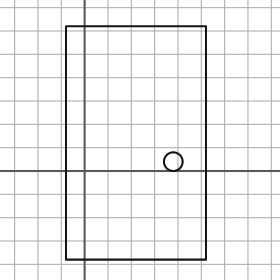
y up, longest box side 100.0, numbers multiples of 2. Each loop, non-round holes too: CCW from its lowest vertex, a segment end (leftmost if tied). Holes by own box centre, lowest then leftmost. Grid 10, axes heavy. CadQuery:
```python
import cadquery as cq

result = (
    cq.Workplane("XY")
    .moveTo(-8.0, -38.0)
    .lineTo(52.0, -38.0)
    .lineTo(52.0, 62.0)
    .lineTo(-8.0, 62.0)
    .close()
    .moveTo(38.0, 4.0)
    .circle(4.0)
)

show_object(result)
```